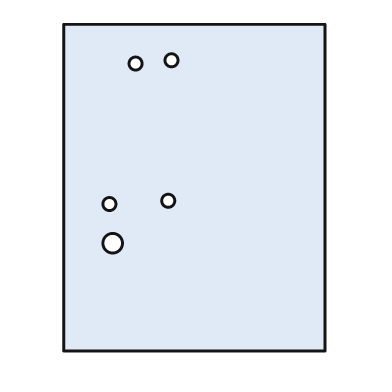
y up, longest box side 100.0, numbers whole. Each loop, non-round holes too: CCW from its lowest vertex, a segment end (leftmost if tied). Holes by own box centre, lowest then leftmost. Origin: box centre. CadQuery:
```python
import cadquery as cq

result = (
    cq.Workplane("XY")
    .moveTo(-40.0, -50.0)
    .lineTo(40.0, -50.0)
    .lineTo(40.0, 50.0)
    .lineTo(-40.0, 50.0)
    .close()
    .moveTo(-25.0, -17.0)
    .circle(3.0)
    .moveTo(-26.0, -5.0)
    .circle(2.0)
    .moveTo(-8.0, -4.0)
    .circle(2.0)
    .moveTo(-18.0, 38.0)
    .circle(2.0)
    .moveTo(-7.0, 39.0)
    .circle(2.0)
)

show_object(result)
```